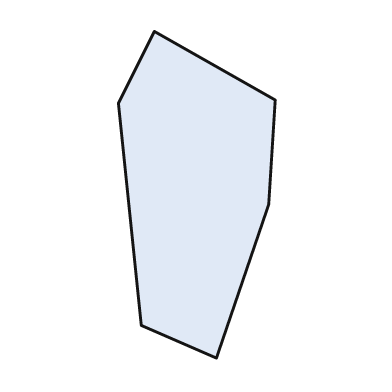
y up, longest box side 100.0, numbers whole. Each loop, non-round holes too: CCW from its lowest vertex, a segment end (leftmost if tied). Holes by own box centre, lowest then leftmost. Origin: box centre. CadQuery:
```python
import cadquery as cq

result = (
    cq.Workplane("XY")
    .moveTo(6.0, -50.0)
    .lineTo(22.0, -3.0)
    .lineTo(24.0, 29.0)
    .lineTo(-13.0, 50.0)
    .lineTo(-24.0, 28.0)
    .lineTo(-17.0, -40.0)
    .close()
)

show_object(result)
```